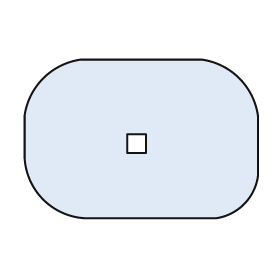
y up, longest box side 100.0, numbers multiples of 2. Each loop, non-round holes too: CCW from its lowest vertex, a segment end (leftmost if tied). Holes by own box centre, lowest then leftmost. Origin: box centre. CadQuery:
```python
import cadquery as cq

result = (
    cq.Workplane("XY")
    .moveTo(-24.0, -34.0)
    .lineTo(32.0, -34.0)
    .threePointArc((44.0, -28.0), (50.0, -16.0))
    .lineTo(50.0, 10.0)
    .threePointArc((42.0, 26.0), (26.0, 34.0))
    .lineTo(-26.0, 34.0)
    .threePointArc((-42.0, 26.0), (-50.0, 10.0))
    .lineTo(-50.0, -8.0)
    .threePointArc((-42.0, -26.0), (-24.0, -34.0))
    .close()
    .moveTo(-6.0, -6.0)
    .lineTo(2.0, -6.0)
    .lineTo(2.0, 2.0)
    .lineTo(-6.0, 2.0)
    .close()
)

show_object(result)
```